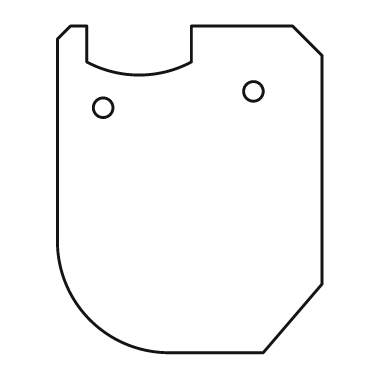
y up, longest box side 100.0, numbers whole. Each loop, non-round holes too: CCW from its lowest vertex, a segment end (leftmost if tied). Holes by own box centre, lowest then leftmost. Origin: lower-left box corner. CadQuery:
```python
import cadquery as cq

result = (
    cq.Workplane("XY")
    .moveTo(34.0, 0.0)
    .lineTo(63.0, 0.0)
    .lineTo(81.0, 21.0)
    .lineTo(81.0, 91.0)
    .lineTo(72.0, 100.0)
    .lineTo(41.0, 100.0)
    .lineTo(41.0, 89.0)
    .threePointArc((25.0, 85.0), (9.0, 89.0))
    .lineTo(9.0, 100.0)
    .lineTo(4.0, 100.0)
    .lineTo(0.0, 96.0)
    .lineTo(0.0, 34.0)
    .threePointArc((10.0, 10.0), (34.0, 0.0))
    .close()
    .moveTo(14.0, 75.0)
    .circle(3.0)
    .moveTo(60.0, 80.0)
    .circle(3.0)
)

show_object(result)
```